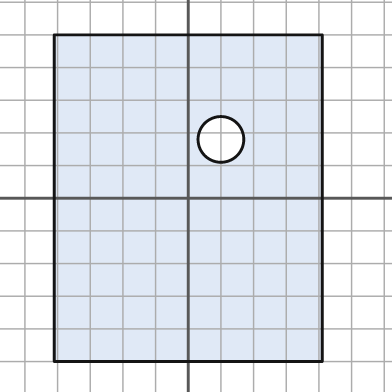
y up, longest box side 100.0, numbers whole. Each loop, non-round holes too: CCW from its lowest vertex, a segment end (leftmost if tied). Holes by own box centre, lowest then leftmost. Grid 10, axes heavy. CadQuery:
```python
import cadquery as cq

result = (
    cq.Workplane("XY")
    .moveTo(-41.0, -50.0)
    .lineTo(41.0, -50.0)
    .lineTo(41.0, 50.0)
    .lineTo(-41.0, 50.0)
    .close()
    .moveTo(10.0, 18.0)
    .circle(7.0)
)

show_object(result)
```